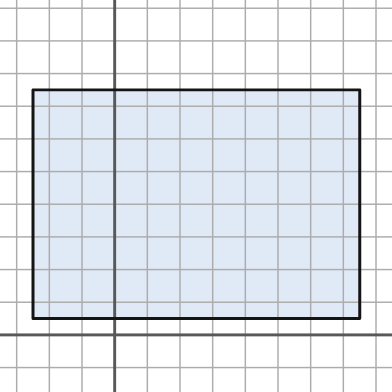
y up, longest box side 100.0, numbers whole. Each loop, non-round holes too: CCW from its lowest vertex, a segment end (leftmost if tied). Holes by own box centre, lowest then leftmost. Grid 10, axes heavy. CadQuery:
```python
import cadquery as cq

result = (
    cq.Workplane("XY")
    .moveTo(-25.0, 5.0)
    .lineTo(75.0, 5.0)
    .lineTo(75.0, 75.0)
    .lineTo(-25.0, 75.0)
    .close()
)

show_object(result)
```